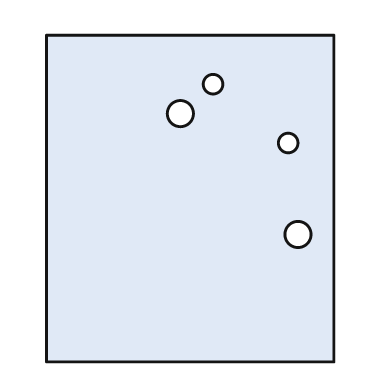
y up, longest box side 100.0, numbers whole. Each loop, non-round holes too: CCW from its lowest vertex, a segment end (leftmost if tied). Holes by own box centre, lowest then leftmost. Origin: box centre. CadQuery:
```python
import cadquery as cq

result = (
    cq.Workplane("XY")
    .moveTo(-44.0, -50.0)
    .lineTo(44.0, -50.0)
    .lineTo(44.0, 50.0)
    .lineTo(-44.0, 50.0)
    .close()
    .moveTo(33.0, -11.0)
    .circle(4.0)
    .moveTo(30.0, 17.0)
    .circle(3.0)
    .moveTo(-3.0, 26.0)
    .circle(4.0)
    .moveTo(7.0, 35.0)
    .circle(3.0)
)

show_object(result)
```